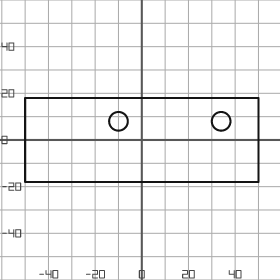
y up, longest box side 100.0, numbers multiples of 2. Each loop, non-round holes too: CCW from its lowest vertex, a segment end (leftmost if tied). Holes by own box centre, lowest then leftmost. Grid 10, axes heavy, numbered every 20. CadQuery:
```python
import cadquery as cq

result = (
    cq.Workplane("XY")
    .moveTo(-50.0, -18.0)
    .lineTo(50.0, -18.0)
    .lineTo(50.0, 18.0)
    .lineTo(-50.0, 18.0)
    .close()
    .moveTo(-10.0, 8.0)
    .circle(4.0)
    .moveTo(34.0, 8.0)
    .circle(4.0)
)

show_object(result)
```